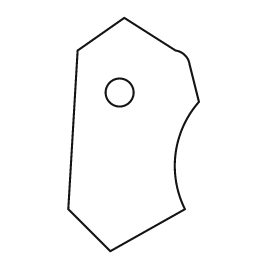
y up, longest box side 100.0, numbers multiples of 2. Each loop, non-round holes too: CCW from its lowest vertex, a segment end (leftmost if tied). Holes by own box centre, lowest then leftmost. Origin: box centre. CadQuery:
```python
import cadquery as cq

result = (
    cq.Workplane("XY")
    .moveTo(-10.0, -50.0)
    .lineTo(22.0, -32.0)
    .threePointArc((18.0, -8.0), (28.0, 14.0))
    .lineTo(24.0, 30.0)
    .threePointArc((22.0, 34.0), (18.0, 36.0))
    .lineTo(-4.0, 50.0)
    .lineTo(-24.0, 36.0)
    .lineTo(-28.0, -32.0)
    .close()
    .moveTo(-6.0, 18.0)
    .circle(6.0)
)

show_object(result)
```